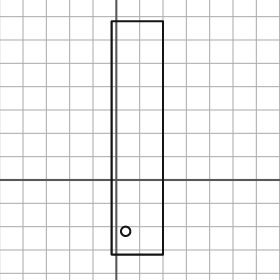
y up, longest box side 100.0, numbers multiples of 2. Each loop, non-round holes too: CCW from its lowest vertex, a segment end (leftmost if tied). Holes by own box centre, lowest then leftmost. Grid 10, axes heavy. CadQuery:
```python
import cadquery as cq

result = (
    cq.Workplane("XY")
    .moveTo(-2.0, -32.0)
    .lineTo(20.0, -32.0)
    .lineTo(20.0, 68.0)
    .lineTo(-2.0, 68.0)
    .close()
    .moveTo(4.0, -22.0)
    .circle(2.0)
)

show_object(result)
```